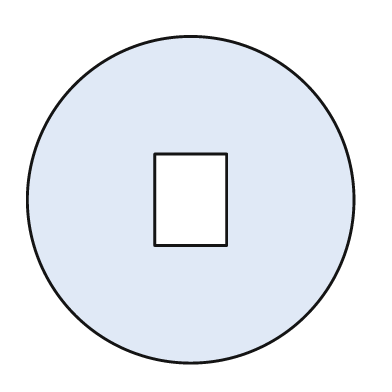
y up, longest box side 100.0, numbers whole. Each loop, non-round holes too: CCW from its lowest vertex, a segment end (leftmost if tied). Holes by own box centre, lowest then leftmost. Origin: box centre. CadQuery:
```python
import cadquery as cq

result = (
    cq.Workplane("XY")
    .moveTo(0.0, 0.0)
    .circle(50.0)
    .moveTo(-11.0, -14.0)
    .lineTo(11.0, -14.0)
    .lineTo(11.0, 14.0)
    .lineTo(-11.0, 14.0)
    .close()
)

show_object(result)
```